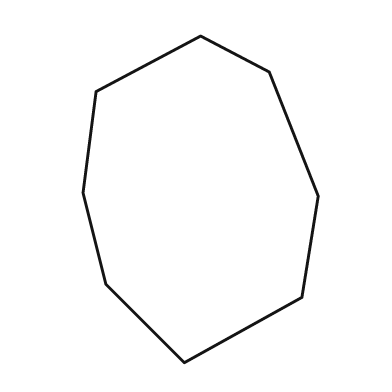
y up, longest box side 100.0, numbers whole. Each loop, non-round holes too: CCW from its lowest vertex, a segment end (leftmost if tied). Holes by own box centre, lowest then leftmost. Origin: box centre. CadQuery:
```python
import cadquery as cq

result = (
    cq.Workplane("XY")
    .moveTo(-5.0, -50.0)
    .lineTo(31.0, -30.0)
    .lineTo(36.0, 1.0)
    .lineTo(21.0, 39.0)
    .lineTo(0.0, 50.0)
    .lineTo(-32.0, 33.0)
    .lineTo(-36.0, 2.0)
    .lineTo(-29.0, -26.0)
    .close()
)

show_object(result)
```